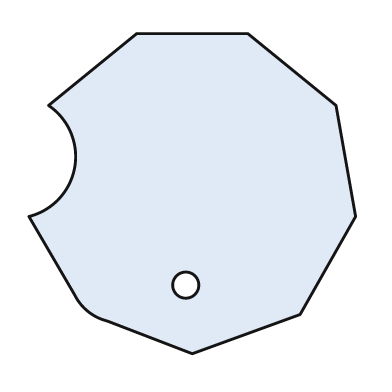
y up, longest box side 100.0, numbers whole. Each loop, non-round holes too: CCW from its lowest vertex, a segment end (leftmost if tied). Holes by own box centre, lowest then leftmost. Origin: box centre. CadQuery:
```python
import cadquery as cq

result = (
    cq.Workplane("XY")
    .moveTo(0.0, -49.0)
    .lineTo(33.0, -37.0)
    .lineTo(50.0, -7.0)
    .lineTo(44.0, 27.0)
    .lineTo(17.0, 49.0)
    .lineTo(-17.0, 49.0)
    .lineTo(-44.0, 27.0)
    .threePointArc((-36.0, 8.0), (-50.0, -7.0))
    .lineTo(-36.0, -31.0)
    .threePointArc((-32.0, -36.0), (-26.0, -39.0))
    .close()
    .moveTo(-2.0, -28.0)
    .circle(4.0)
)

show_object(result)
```